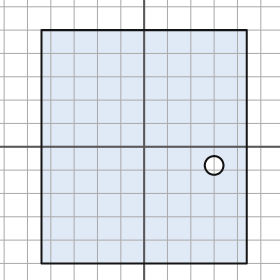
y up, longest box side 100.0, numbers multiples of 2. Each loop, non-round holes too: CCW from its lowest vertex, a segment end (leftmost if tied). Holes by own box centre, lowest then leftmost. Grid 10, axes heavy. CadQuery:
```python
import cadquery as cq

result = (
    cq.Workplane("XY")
    .moveTo(-44.0, -50.0)
    .lineTo(44.0, -50.0)
    .lineTo(44.0, 50.0)
    .lineTo(-44.0, 50.0)
    .close()
    .moveTo(30.0, -8.0)
    .circle(4.0)
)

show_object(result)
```